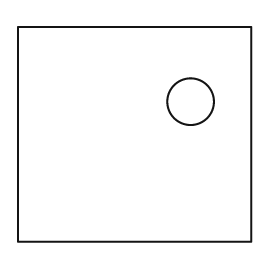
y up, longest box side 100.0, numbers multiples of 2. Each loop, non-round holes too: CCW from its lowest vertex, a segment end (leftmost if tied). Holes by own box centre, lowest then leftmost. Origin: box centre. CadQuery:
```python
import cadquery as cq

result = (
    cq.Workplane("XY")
    .moveTo(-50.0, -46.0)
    .lineTo(50.0, -46.0)
    .lineTo(50.0, 46.0)
    .lineTo(-50.0, 46.0)
    .close()
    .moveTo(24.0, 14.0)
    .circle(10.0)
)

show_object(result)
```